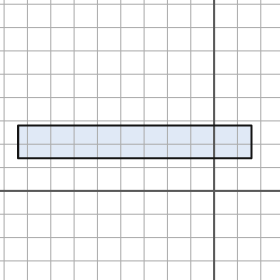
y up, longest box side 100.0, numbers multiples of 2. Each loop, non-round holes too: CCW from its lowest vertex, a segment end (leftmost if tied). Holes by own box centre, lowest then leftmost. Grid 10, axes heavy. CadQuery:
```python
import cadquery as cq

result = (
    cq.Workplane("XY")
    .moveTo(-84.0, 14.0)
    .lineTo(16.0, 14.0)
    .lineTo(16.0, 28.0)
    .lineTo(-84.0, 28.0)
    .close()
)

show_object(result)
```